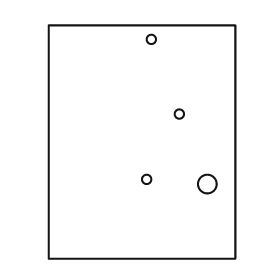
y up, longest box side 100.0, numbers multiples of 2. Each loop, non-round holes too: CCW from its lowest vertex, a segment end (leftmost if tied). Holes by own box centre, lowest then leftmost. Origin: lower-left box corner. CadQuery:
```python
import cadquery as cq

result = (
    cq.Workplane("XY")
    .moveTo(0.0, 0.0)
    .lineTo(80.0, 0.0)
    .lineTo(80.0, 100.0)
    .lineTo(0.0, 100.0)
    .close()
    .moveTo(68.0, 32.0)
    .circle(4.0)
    .moveTo(42.0, 34.0)
    .circle(2.0)
    .moveTo(56.0, 62.0)
    .circle(2.0)
    .moveTo(44.0, 94.0)
    .circle(2.0)
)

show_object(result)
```